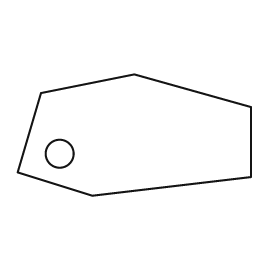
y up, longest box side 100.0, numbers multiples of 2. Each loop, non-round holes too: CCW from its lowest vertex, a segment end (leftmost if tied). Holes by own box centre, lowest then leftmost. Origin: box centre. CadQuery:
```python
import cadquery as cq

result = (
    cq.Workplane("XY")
    .moveTo(-18.0, -26.0)
    .lineTo(50.0, -18.0)
    .lineTo(50.0, 12.0)
    .lineTo(0.0, 26.0)
    .lineTo(-40.0, 18.0)
    .lineTo(-50.0, -16.0)
    .close()
    .moveTo(-32.0, -8.0)
    .circle(6.0)
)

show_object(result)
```